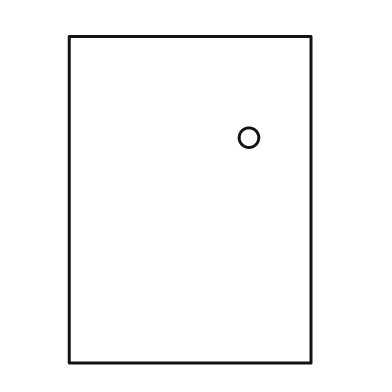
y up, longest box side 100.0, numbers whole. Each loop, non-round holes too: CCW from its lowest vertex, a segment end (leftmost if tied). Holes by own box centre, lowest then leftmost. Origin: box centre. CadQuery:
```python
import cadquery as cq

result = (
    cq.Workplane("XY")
    .moveTo(-37.0, -50.0)
    .lineTo(37.0, -50.0)
    .lineTo(37.0, 50.0)
    .lineTo(-37.0, 50.0)
    .close()
    .moveTo(18.0, 19.0)
    .circle(3.0)
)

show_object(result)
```